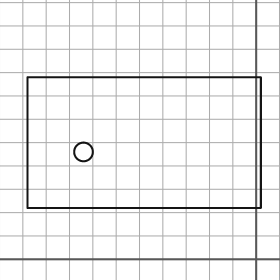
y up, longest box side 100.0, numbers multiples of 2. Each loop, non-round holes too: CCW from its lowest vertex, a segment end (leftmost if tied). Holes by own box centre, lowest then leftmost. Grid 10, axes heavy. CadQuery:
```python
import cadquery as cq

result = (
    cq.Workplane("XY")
    .moveTo(-98.0, 22.0)
    .lineTo(2.0, 22.0)
    .lineTo(2.0, 78.0)
    .lineTo(-98.0, 78.0)
    .close()
    .moveTo(-74.0, 46.0)
    .circle(4.0)
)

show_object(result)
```